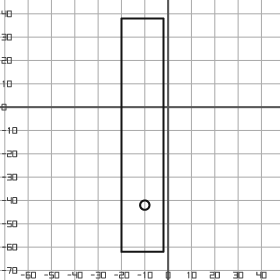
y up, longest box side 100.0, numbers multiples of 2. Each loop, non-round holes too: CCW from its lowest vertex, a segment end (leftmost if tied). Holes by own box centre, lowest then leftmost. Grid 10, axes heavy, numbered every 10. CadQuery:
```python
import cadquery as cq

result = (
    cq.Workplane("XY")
    .moveTo(-20.0, -62.0)
    .lineTo(-2.0, -62.0)
    .lineTo(-2.0, 38.0)
    .lineTo(-20.0, 38.0)
    .close()
    .moveTo(-10.0, -42.0)
    .circle(2.0)
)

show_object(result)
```